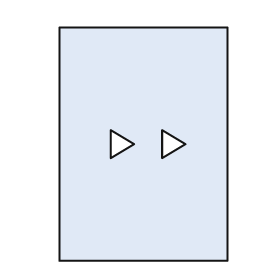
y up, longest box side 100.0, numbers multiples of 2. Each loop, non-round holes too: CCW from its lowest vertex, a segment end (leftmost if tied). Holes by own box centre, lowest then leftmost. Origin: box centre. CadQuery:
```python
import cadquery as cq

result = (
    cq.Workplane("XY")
    .moveTo(-36.0, -50.0)
    .lineTo(36.0, -50.0)
    .lineTo(36.0, 50.0)
    .lineTo(-36.0, 50.0)
    .close()
    .moveTo(-14.0, -6.0)
    .lineTo(-4.0, 0.0)
    .lineTo(-14.0, 6.0)
    .close()
    .moveTo(8.0, -6.0)
    .lineTo(18.0, 0.0)
    .lineTo(8.0, 6.0)
    .close()
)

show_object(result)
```